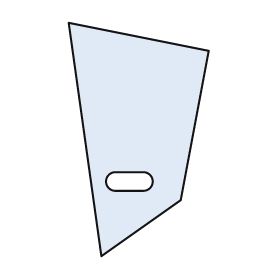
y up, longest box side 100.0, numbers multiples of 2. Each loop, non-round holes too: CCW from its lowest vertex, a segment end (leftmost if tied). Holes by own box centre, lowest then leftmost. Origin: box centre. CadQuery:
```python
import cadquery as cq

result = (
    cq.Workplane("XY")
    .moveTo(-16.0, -50.0)
    .lineTo(18.0, -26.0)
    .lineTo(30.0, 38.0)
    .lineTo(-30.0, 50.0)
    .close()
    .moveTo(-10.0, -22.0)
    .lineTo(2.0, -22.0)
    .threePointArc((6.0, -18.0), (2.0, -14.0))
    .lineTo(-10.0, -14.0)
    .threePointArc((-14.0, -18.0), (-10.0, -22.0))
    .close()
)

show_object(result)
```